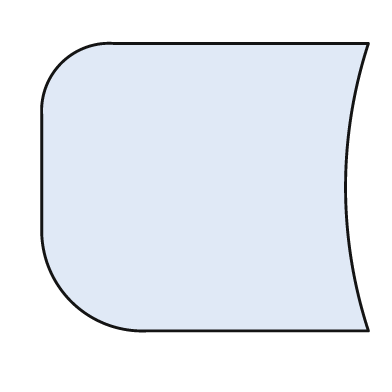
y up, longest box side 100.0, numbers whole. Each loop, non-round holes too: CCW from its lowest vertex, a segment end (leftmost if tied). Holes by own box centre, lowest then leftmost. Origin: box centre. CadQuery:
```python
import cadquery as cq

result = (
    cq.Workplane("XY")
    .moveTo(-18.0, -44.0)
    .lineTo(50.0, -44.0)
    .threePointArc((43.0, 0.0), (50.0, 44.0))
    .lineTo(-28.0, 44.0)
    .threePointArc((-44.0, 38.0), (-50.0, 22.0))
    .lineTo(-50.0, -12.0)
    .threePointArc((-41.0, -35.0), (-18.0, -44.0))
    .close()
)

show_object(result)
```